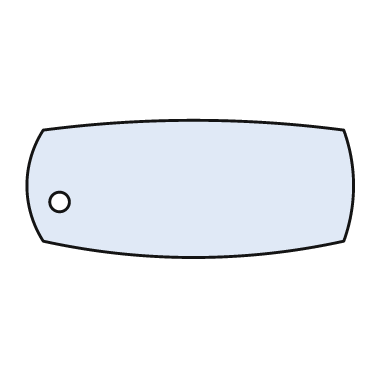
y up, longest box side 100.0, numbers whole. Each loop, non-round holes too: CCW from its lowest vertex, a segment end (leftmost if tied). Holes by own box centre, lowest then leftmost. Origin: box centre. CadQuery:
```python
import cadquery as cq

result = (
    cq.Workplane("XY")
    .moveTo(-45.0, -16.0)
    .threePointArc((1.0, -21.0), (47.0, -16.0))
    .threePointArc((50.0, 1.0), (47.0, 18.0))
    .threePointArc((1.0, 21.0), (-45.0, 18.0))
    .threePointArc((-50.0, 1.0), (-45.0, -16.0))
    .close()
    .moveTo(-40.0, -4.0)
    .circle(3.0)
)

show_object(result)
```